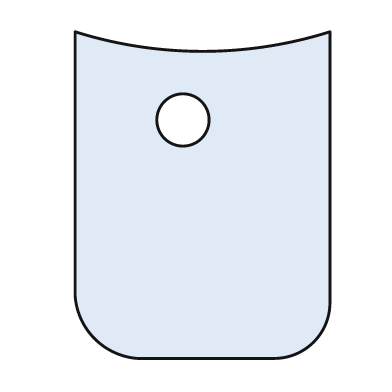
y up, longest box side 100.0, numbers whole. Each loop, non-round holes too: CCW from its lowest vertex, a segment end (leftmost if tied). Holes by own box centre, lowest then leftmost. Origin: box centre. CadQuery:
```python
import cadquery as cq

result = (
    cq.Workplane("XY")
    .moveTo(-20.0, -50.0)
    .lineTo(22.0, -50.0)
    .threePointArc((34.0, -45.0), (39.0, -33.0))
    .lineTo(39.0, 50.0)
    .threePointArc((0.0, 44.0), (-39.0, 50.0))
    .lineTo(-39.0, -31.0)
    .threePointArc((-33.0, -44.0), (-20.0, -50.0))
    .close()
    .moveTo(-6.0, 23.0)
    .circle(8.0)
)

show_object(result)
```